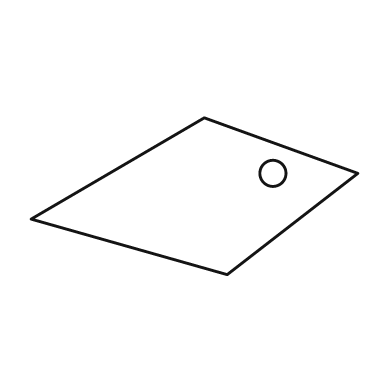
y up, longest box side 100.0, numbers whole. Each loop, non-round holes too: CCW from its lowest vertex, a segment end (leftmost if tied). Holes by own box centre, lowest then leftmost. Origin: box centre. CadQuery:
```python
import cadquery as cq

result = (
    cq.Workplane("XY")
    .moveTo(10.0, -24.0)
    .lineTo(50.0, 7.0)
    .lineTo(3.0, 24.0)
    .lineTo(-50.0, -7.0)
    .close()
    .moveTo(24.0, 7.0)
    .circle(4.0)
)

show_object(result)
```